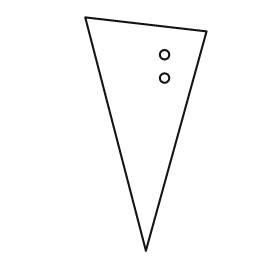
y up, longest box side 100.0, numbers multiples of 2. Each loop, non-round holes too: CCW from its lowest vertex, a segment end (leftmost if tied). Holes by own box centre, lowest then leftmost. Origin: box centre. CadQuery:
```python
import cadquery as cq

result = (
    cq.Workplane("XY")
    .moveTo(0.0, -50.0)
    .lineTo(26.0, 44.0)
    .lineTo(-26.0, 50.0)
    .close()
    .moveTo(8.0, 24.0)
    .circle(2.0)
    .moveTo(8.0, 34.0)
    .circle(2.0)
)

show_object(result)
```